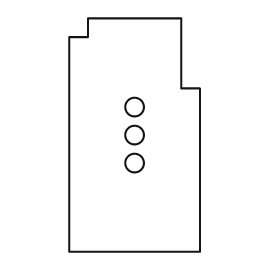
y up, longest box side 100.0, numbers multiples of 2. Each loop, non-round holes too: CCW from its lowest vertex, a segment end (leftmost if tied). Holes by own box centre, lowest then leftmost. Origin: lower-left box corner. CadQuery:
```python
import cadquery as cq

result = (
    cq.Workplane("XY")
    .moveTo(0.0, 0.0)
    .lineTo(56.0, 0.0)
    .lineTo(56.0, 70.0)
    .lineTo(48.0, 70.0)
    .lineTo(48.0, 100.0)
    .lineTo(8.0, 100.0)
    .lineTo(8.0, 92.0)
    .lineTo(0.0, 92.0)
    .close()
    .moveTo(28.0, 38.0)
    .circle(4.0)
    .moveTo(28.0, 50.0)
    .circle(4.0)
    .moveTo(28.0, 62.0)
    .circle(4.0)
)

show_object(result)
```